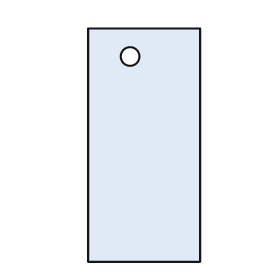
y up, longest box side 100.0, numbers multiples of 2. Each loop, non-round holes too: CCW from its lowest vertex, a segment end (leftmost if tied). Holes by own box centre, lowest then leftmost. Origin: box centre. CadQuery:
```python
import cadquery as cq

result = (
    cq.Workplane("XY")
    .moveTo(-24.0, -50.0)
    .lineTo(24.0, -50.0)
    .lineTo(24.0, 50.0)
    .lineTo(-24.0, 50.0)
    .close()
    .moveTo(-6.0, 38.0)
    .circle(4.0)
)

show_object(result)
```